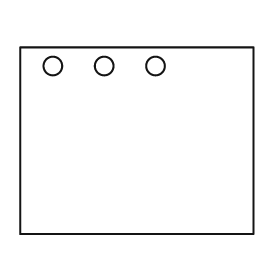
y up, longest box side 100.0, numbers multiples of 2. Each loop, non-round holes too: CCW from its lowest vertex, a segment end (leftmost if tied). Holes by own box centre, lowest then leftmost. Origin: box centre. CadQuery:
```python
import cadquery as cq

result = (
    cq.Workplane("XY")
    .moveTo(-50.0, -40.0)
    .lineTo(50.0, -40.0)
    .lineTo(50.0, 40.0)
    .lineTo(-50.0, 40.0)
    .close()
    .moveTo(-36.0, 32.0)
    .circle(4.0)
    .moveTo(-14.0, 32.0)
    .circle(4.0)
    .moveTo(8.0, 32.0)
    .circle(4.0)
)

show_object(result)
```